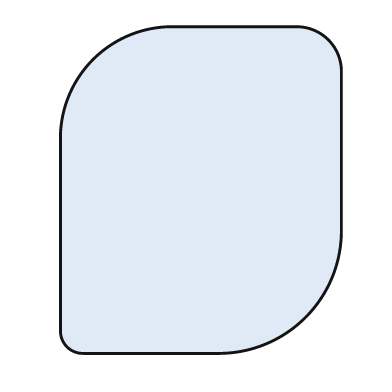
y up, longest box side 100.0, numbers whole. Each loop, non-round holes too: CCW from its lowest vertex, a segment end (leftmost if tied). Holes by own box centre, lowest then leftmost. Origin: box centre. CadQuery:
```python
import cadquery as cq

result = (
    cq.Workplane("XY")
    .moveTo(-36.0, -50.0)
    .lineTo(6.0, -50.0)
    .threePointArc((32.0, -39.0), (43.0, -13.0))
    .lineTo(43.0, 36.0)
    .threePointArc((39.0, 46.0), (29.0, 50.0))
    .lineTo(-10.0, 50.0)
    .threePointArc((-33.0, 40.0), (-43.0, 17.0))
    .lineTo(-43.0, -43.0)
    .threePointArc((-41.0, -48.0), (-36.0, -50.0))
    .close()
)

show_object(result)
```